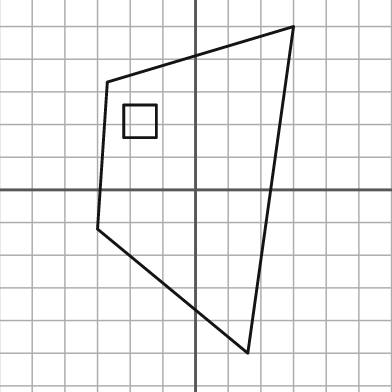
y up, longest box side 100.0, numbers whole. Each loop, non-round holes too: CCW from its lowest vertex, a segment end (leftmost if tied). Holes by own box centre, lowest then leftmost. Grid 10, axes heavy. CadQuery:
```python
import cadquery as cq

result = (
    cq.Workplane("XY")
    .moveTo(16.0, -50.0)
    .lineTo(30.0, 50.0)
    .lineTo(-27.0, 33.0)
    .lineTo(-30.0, -12.0)
    .close()
    .moveTo(-22.0, 16.0)
    .lineTo(-12.0, 16.0)
    .lineTo(-12.0, 26.0)
    .lineTo(-22.0, 26.0)
    .close()
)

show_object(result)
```